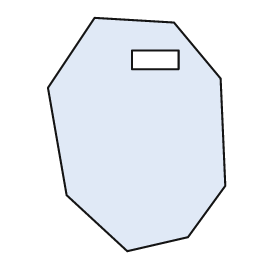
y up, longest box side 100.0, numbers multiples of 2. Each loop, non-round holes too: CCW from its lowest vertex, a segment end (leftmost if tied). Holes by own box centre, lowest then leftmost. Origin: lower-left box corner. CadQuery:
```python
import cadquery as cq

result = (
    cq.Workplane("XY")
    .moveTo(34.0, 0.0)
    .lineTo(60.0, 6.0)
    .lineTo(76.0, 28.0)
    .lineTo(74.0, 74.0)
    .lineTo(54.0, 98.0)
    .lineTo(20.0, 100.0)
    .lineTo(0.0, 70.0)
    .lineTo(8.0, 24.0)
    .close()
    .moveTo(36.0, 78.0)
    .lineTo(56.0, 78.0)
    .lineTo(56.0, 86.0)
    .lineTo(36.0, 86.0)
    .close()
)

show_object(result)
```